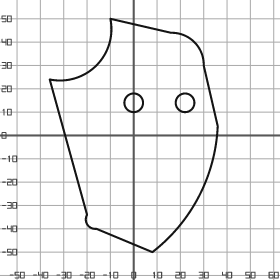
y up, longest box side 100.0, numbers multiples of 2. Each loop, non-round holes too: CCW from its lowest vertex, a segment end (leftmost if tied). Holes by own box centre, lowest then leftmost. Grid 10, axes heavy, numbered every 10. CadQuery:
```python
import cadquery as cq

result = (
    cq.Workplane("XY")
    .moveTo(8.0, -50.0)
    .threePointArc((28.0, -26.0), (36.0, 4.0))
    .lineTo(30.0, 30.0)
    .threePointArc((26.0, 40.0), (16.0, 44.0))
    .lineTo(-10.0, 50.0)
    .threePointArc((-16.0, 30.0), (-36.0, 24.0))
    .lineTo(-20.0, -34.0)
    .threePointArc((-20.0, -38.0), (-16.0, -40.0))
    .close()
    .moveTo(0.0, 14.0)
    .circle(4.0)
    .moveTo(22.0, 14.0)
    .circle(4.0)
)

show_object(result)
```